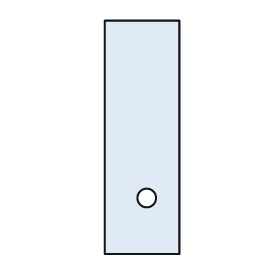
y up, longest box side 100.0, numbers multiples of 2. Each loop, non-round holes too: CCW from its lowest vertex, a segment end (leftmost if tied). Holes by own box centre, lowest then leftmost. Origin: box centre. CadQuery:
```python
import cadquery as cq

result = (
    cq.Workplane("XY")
    .moveTo(-16.0, -50.0)
    .lineTo(16.0, -50.0)
    .lineTo(16.0, 50.0)
    .lineTo(-16.0, 50.0)
    .close()
    .moveTo(2.0, -26.0)
    .circle(4.0)
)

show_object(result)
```